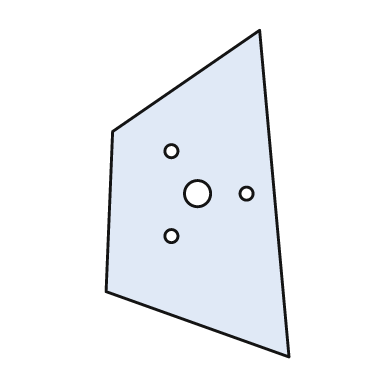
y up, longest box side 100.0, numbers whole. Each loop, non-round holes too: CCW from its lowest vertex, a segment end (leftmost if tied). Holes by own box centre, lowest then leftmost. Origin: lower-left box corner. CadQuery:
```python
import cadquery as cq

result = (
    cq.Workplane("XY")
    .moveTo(56.0, 0.0)
    .lineTo(47.0, 100.0)
    .lineTo(2.0, 69.0)
    .lineTo(0.0, 20.0)
    .close()
    .moveTo(20.0, 37.0)
    .circle(2.0)
    .moveTo(28.0, 50.0)
    .circle(4.0)
    .moveTo(43.0, 50.0)
    .circle(2.0)
    .moveTo(20.0, 63.0)
    .circle(2.0)
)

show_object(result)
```